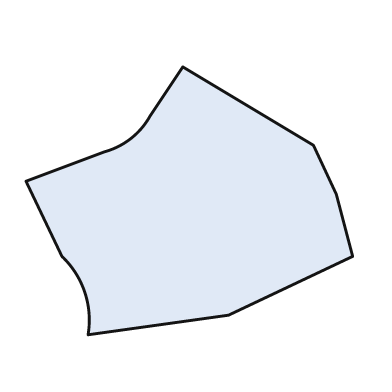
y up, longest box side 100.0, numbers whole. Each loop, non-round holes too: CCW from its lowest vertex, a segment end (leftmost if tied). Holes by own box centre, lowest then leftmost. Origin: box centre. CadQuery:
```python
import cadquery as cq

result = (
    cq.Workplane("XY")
    .moveTo(-31.0, -41.0)
    .lineTo(12.0, -35.0)
    .lineTo(50.0, -17.0)
    .lineTo(45.0, 2.0)
    .lineTo(38.0, 17.0)
    .lineTo(-2.0, 41.0)
    .lineTo(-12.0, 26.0)
    .threePointArc((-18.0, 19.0), (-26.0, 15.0))
    .lineTo(-50.0, 6.0)
    .lineTo(-39.0, -17.0)
    .threePointArc((-32.0, -28.0), (-31.0, -41.0))
    .close()
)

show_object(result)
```